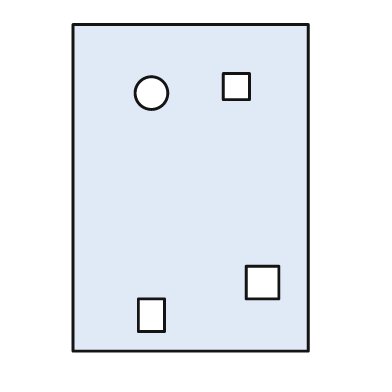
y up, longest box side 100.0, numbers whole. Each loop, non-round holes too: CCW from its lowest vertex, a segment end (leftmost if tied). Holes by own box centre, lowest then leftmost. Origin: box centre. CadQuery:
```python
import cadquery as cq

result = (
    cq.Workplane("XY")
    .moveTo(-36.0, -50.0)
    .lineTo(36.0, -50.0)
    .lineTo(36.0, 50.0)
    .lineTo(-36.0, 50.0)
    .close()
    .moveTo(-16.0, -44.0)
    .lineTo(-8.0, -44.0)
    .lineTo(-8.0, -34.0)
    .lineTo(-16.0, -34.0)
    .close()
    .moveTo(17.0, -34.0)
    .lineTo(27.0, -34.0)
    .lineTo(27.0, -24.0)
    .lineTo(17.0, -24.0)
    .close()
    .moveTo(-12.0, 29.0)
    .circle(5.0)
    .moveTo(10.0, 27.0)
    .lineTo(18.0, 27.0)
    .lineTo(18.0, 35.0)
    .lineTo(10.0, 35.0)
    .close()
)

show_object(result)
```